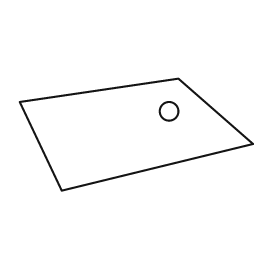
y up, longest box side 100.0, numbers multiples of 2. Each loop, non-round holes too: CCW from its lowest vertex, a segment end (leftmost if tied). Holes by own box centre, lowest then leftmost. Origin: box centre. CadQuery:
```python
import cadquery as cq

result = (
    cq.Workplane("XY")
    .moveTo(-32.0, -24.0)
    .lineTo(50.0, -4.0)
    .lineTo(18.0, 24.0)
    .lineTo(-50.0, 14.0)
    .close()
    .moveTo(14.0, 10.0)
    .circle(4.0)
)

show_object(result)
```